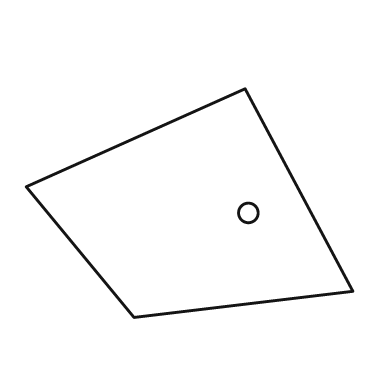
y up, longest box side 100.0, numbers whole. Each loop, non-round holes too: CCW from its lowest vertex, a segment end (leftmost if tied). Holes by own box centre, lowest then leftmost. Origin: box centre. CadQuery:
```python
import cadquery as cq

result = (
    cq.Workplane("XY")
    .moveTo(-17.0, -35.0)
    .lineTo(50.0, -27.0)
    .lineTo(17.0, 35.0)
    .lineTo(-50.0, 5.0)
    .close()
    .moveTo(18.0, -3.0)
    .circle(3.0)
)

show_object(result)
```